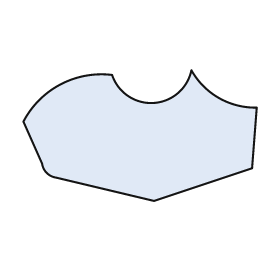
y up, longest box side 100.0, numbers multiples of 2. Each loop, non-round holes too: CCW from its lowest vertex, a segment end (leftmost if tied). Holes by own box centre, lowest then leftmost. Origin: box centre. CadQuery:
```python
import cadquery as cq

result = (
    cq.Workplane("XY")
    .moveTo(6.0, -28.0)
    .lineTo(48.0, -14.0)
    .lineTo(50.0, 12.0)
    .threePointArc((34.0, 16.0), (22.0, 28.0))
    .threePointArc((6.0, 14.0), (-12.0, 26.0))
    .threePointArc((-34.0, 22.0), (-50.0, 6.0))
    .lineTo(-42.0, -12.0)
    .threePointArc((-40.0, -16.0), (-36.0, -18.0))
    .close()
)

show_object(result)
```